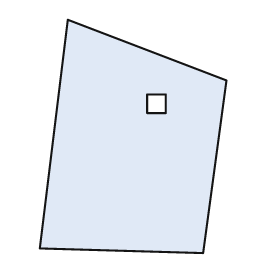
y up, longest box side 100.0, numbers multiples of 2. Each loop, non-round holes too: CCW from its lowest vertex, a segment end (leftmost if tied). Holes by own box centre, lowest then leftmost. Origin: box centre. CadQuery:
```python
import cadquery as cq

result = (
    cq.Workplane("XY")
    .moveTo(30.0, -50.0)
    .lineTo(40.0, 24.0)
    .lineTo(-28.0, 50.0)
    .lineTo(-40.0, -48.0)
    .close()
    .moveTo(6.0, 10.0)
    .lineTo(14.0, 10.0)
    .lineTo(14.0, 18.0)
    .lineTo(6.0, 18.0)
    .close()
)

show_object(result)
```